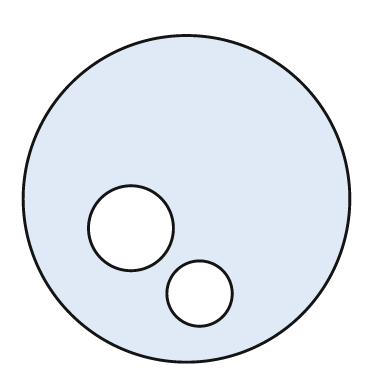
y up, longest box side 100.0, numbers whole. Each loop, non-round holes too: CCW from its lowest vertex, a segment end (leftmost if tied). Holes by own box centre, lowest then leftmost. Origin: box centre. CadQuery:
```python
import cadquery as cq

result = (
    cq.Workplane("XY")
    .moveTo(0.0, 0.0)
    .circle(50.0)
    .moveTo(4.0, -29.0)
    .circle(10.0)
    .moveTo(-17.0, -9.0)
    .circle(13.0)
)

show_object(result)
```